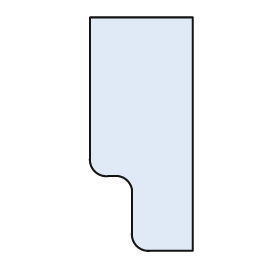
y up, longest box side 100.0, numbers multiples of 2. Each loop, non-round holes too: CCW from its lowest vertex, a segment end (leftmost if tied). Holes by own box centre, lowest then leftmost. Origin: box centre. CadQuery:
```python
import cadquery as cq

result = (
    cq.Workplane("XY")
    .moveTo(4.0, -50.0)
    .lineTo(22.0, -50.0)
    .lineTo(22.0, 50.0)
    .lineTo(-22.0, 50.0)
    .lineTo(-22.0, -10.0)
    .threePointArc((-20.0, -16.0), (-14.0, -18.0))
    .lineTo(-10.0, -18.0)
    .threePointArc((-6.0, -20.0), (-4.0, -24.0))
    .lineTo(-4.0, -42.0)
    .threePointArc((-2.0, -48.0), (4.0, -50.0))
    .close()
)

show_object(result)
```